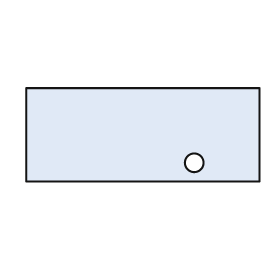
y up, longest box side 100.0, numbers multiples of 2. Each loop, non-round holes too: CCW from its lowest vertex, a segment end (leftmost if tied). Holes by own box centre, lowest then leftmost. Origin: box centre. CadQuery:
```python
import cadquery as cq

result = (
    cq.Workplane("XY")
    .moveTo(-50.0, -20.0)
    .lineTo(50.0, -20.0)
    .lineTo(50.0, 20.0)
    .lineTo(-50.0, 20.0)
    .close()
    .moveTo(22.0, -12.0)
    .circle(4.0)
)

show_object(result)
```